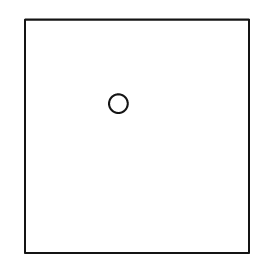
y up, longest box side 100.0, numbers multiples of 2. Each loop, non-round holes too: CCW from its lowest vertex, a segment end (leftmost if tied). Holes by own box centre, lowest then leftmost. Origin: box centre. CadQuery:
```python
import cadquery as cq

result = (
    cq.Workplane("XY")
    .moveTo(-48.0, -50.0)
    .lineTo(48.0, -50.0)
    .lineTo(48.0, 50.0)
    .lineTo(-48.0, 50.0)
    .close()
    .moveTo(-8.0, 14.0)
    .circle(4.0)
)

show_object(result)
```